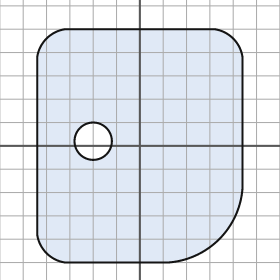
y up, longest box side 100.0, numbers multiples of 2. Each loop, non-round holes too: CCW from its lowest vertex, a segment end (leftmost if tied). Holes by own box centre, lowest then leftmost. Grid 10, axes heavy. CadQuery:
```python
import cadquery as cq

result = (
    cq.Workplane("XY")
    .moveTo(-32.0, -50.0)
    .lineTo(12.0, -50.0)
    .threePointArc((34.0, -40.0), (44.0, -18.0))
    .lineTo(44.0, 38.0)
    .threePointArc((40.0, 46.0), (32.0, 50.0))
    .lineTo(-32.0, 50.0)
    .threePointArc((-40.0, 46.0), (-44.0, 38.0))
    .lineTo(-44.0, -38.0)
    .threePointArc((-40.0, -46.0), (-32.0, -50.0))
    .close()
    .moveTo(-20.0, 2.0)
    .circle(8.0)
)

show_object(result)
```